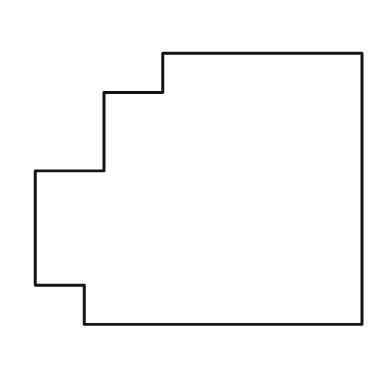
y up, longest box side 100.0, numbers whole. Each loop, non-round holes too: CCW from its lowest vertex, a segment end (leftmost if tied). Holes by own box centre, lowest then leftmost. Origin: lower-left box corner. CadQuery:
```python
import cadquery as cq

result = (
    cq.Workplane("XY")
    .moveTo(15.0, 0.0)
    .lineTo(100.0, 0.0)
    .lineTo(100.0, 83.0)
    .lineTo(39.0, 83.0)
    .lineTo(39.0, 71.0)
    .lineTo(21.0, 71.0)
    .lineTo(21.0, 47.0)
    .lineTo(0.0, 47.0)
    .lineTo(0.0, 12.0)
    .lineTo(15.0, 12.0)
    .close()
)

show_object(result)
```